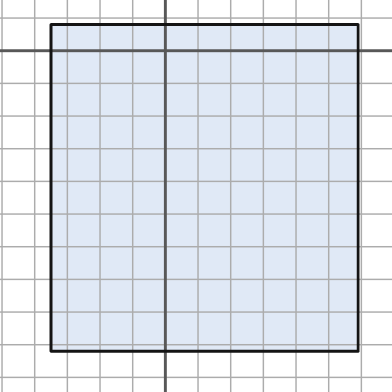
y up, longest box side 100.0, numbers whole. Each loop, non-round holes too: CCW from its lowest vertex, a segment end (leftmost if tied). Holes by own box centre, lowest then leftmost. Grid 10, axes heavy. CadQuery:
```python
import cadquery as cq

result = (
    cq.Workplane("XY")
    .moveTo(-35.0, -92.0)
    .lineTo(59.0, -92.0)
    .lineTo(59.0, 8.0)
    .lineTo(-35.0, 8.0)
    .close()
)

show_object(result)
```